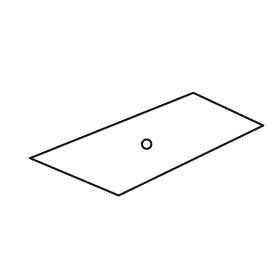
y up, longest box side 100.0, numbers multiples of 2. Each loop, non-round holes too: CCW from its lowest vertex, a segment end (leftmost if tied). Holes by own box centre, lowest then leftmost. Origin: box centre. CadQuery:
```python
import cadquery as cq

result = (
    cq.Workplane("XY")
    .moveTo(-12.0, -22.0)
    .lineTo(50.0, 8.0)
    .lineTo(20.0, 22.0)
    .lineTo(-50.0, -6.0)
    .close()
    .moveTo(0.0, 0.0)
    .circle(2.0)
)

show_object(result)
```